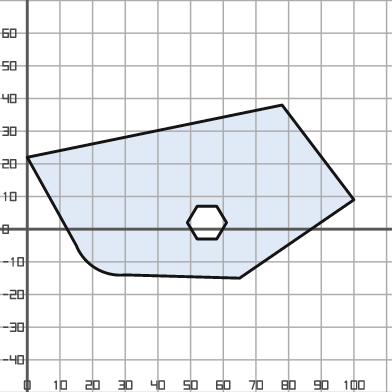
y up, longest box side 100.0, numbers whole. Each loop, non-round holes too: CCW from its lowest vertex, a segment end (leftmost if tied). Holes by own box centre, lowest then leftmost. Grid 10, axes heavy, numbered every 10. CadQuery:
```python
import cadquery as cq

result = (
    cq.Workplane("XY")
    .moveTo(65.0, -15.0)
    .lineTo(100.0, 9.0)
    .lineTo(78.0, 38.0)
    .lineTo(0.0, 22.0)
    .lineTo(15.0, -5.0)
    .threePointArc((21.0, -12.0), (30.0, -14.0))
    .close()
    .moveTo(52.0, -3.0)
    .lineTo(58.0, -3.0)
    .lineTo(61.0, 2.0)
    .lineTo(58.0, 7.0)
    .lineTo(52.0, 7.0)
    .lineTo(49.0, 2.0)
    .close()
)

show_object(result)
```